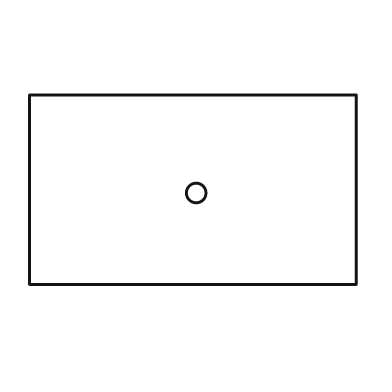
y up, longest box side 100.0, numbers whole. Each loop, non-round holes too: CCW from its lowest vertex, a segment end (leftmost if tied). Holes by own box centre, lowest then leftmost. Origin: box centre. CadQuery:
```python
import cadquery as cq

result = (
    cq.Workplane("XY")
    .moveTo(-50.0, -29.0)
    .lineTo(50.0, -29.0)
    .lineTo(50.0, 29.0)
    .lineTo(-50.0, 29.0)
    .close()
    .moveTo(1.0, -1.0)
    .circle(3.0)
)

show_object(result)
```